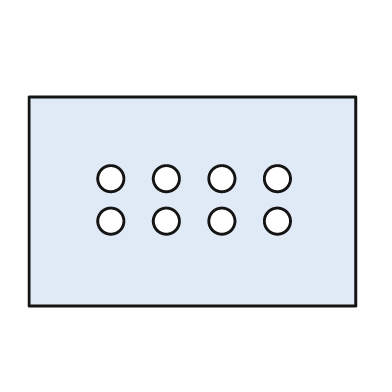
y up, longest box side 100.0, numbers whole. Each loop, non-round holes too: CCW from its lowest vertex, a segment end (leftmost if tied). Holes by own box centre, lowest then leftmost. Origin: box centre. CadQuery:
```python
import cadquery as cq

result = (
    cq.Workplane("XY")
    .moveTo(-50.0, -32.0)
    .lineTo(50.0, -32.0)
    .lineTo(50.0, 32.0)
    .lineTo(-50.0, 32.0)
    .close()
    .moveTo(-25.0, -6.0)
    .circle(4.0)
    .moveTo(-8.0, -6.0)
    .circle(4.0)
    .moveTo(9.0, -6.0)
    .circle(4.0)
    .moveTo(26.0, -6.0)
    .circle(4.0)
    .moveTo(-25.0, 7.0)
    .circle(4.0)
    .moveTo(-8.0, 7.0)
    .circle(4.0)
    .moveTo(9.0, 7.0)
    .circle(4.0)
    .moveTo(26.0, 7.0)
    .circle(4.0)
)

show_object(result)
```